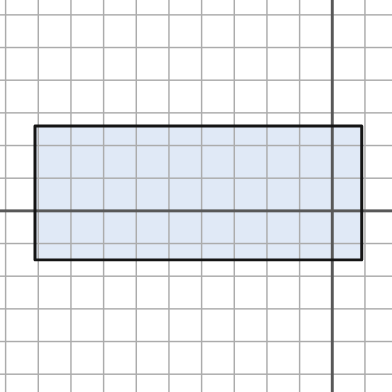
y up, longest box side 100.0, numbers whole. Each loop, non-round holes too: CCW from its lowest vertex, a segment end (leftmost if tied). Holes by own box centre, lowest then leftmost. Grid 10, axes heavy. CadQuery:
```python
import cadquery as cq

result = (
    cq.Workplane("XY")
    .moveTo(-91.0, -15.0)
    .lineTo(9.0, -15.0)
    .lineTo(9.0, 26.0)
    .lineTo(-91.0, 26.0)
    .close()
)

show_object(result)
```